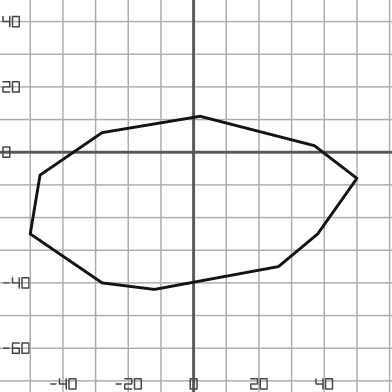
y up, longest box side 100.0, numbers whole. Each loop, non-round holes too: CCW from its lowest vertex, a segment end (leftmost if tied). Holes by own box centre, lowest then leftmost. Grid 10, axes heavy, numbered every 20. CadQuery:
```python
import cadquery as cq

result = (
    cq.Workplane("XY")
    .moveTo(-12.0, -42.0)
    .lineTo(26.0, -35.0)
    .lineTo(38.0, -25.0)
    .lineTo(50.0, -8.0)
    .lineTo(37.0, 2.0)
    .lineTo(2.0, 11.0)
    .lineTo(-28.0, 6.0)
    .lineTo(-47.0, -7.0)
    .lineTo(-50.0, -25.0)
    .lineTo(-28.0, -40.0)
    .close()
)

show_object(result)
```